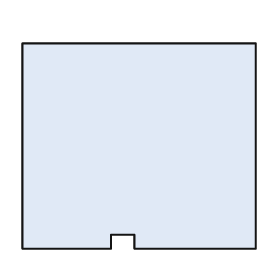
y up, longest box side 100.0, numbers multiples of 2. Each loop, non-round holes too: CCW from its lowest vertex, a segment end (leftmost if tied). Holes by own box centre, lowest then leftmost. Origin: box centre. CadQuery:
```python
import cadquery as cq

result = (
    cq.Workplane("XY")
    .moveTo(-50.0, -44.0)
    .lineTo(-12.0, -44.0)
    .lineTo(-12.0, -38.0)
    .lineTo(-2.0, -38.0)
    .lineTo(-2.0, -44.0)
    .lineTo(50.0, -44.0)
    .lineTo(50.0, 44.0)
    .lineTo(-50.0, 44.0)
    .close()
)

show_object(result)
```